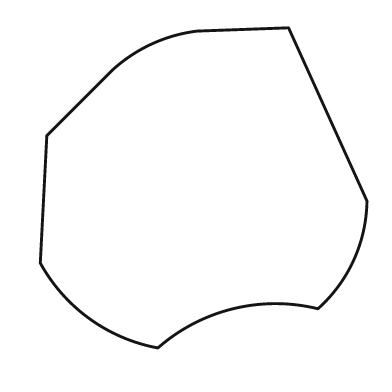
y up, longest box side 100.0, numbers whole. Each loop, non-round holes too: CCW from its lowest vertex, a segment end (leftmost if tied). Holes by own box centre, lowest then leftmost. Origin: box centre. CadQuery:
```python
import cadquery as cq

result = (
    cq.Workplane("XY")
    .moveTo(-14.0, -49.0)
    .threePointArc((9.0, -37.0), (35.0, -37.0))
    .threePointArc((46.0, -22.0), (50.0, -4.0))
    .lineTo(26.0, 49.0)
    .lineTo(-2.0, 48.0)
    .threePointArc((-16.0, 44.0), (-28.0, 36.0))
    .lineTo(-48.0, 16.0)
    .lineTo(-50.0, -23.0)
    .threePointArc((-35.0, -40.0), (-14.0, -49.0))
    .close()
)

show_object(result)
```